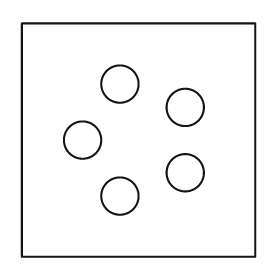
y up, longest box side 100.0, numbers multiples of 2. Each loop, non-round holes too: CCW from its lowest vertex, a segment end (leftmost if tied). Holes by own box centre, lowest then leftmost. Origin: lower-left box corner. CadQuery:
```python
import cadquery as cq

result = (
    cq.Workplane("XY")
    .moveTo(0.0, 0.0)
    .lineTo(100.0, 0.0)
    .lineTo(100.0, 100.0)
    .lineTo(0.0, 100.0)
    .close()
    .moveTo(42.0, 26.0)
    .circle(8.0)
    .moveTo(70.0, 36.0)
    .circle(8.0)
    .moveTo(26.0, 50.0)
    .circle(8.0)
    .moveTo(70.0, 64.0)
    .circle(8.0)
    .moveTo(42.0, 74.0)
    .circle(8.0)
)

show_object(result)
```